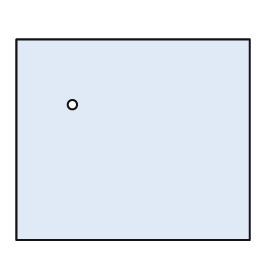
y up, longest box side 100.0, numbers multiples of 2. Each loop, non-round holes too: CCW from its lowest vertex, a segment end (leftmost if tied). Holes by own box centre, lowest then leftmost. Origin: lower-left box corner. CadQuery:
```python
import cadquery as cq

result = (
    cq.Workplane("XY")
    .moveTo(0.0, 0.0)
    .lineTo(100.0, 0.0)
    .lineTo(100.0, 86.0)
    .lineTo(0.0, 86.0)
    .close()
    .moveTo(24.0, 58.0)
    .circle(2.0)
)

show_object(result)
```